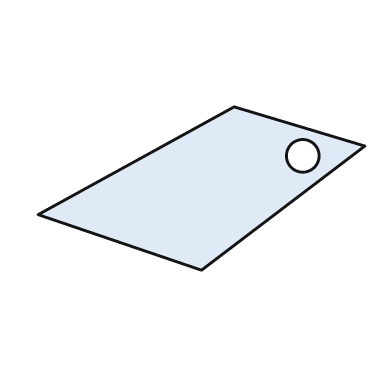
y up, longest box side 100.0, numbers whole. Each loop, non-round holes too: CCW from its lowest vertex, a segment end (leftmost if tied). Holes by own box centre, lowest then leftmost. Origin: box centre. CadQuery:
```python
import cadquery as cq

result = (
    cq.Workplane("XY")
    .moveTo(0.0, -25.0)
    .lineTo(50.0, 13.0)
    .lineTo(10.0, 25.0)
    .lineTo(-50.0, -8.0)
    .close()
    .moveTo(31.0, 10.0)
    .circle(5.0)
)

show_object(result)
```